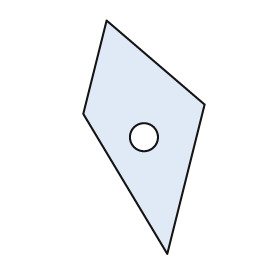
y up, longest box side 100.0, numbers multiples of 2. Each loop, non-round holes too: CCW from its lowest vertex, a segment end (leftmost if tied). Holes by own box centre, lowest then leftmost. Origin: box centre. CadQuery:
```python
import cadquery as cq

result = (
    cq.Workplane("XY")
    .moveTo(10.0, -50.0)
    .lineTo(26.0, 14.0)
    .lineTo(-16.0, 50.0)
    .lineTo(-26.0, 10.0)
    .close()
    .moveTo(0.0, 0.0)
    .circle(6.0)
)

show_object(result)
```